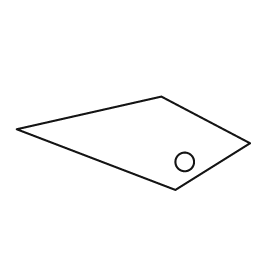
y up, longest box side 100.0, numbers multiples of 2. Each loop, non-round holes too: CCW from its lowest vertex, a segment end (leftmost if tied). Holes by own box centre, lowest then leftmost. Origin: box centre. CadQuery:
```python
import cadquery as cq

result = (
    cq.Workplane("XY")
    .moveTo(18.0, -20.0)
    .lineTo(50.0, 0.0)
    .lineTo(12.0, 20.0)
    .lineTo(-50.0, 6.0)
    .close()
    .moveTo(22.0, -8.0)
    .circle(4.0)
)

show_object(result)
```